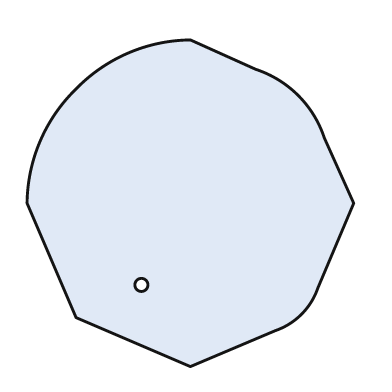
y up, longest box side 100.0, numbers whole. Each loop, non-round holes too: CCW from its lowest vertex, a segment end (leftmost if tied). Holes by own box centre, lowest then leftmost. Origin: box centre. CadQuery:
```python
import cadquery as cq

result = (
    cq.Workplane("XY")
    .moveTo(0.0, -50.0)
    .lineTo(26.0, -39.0)
    .threePointArc((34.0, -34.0), (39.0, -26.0))
    .lineTo(50.0, 0.0)
    .lineTo(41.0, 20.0)
    .threePointArc((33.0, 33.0), (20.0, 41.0))
    .lineTo(0.0, 50.0)
    .threePointArc((-19.0, 46.0), (-35.0, 35.0))
    .threePointArc((-46.0, 19.0), (-50.0, 0.0))
    .lineTo(-35.0, -35.0)
    .close()
    .moveTo(-15.0, -25.0)
    .circle(2.0)
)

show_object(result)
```